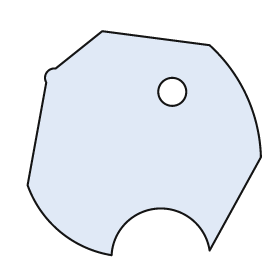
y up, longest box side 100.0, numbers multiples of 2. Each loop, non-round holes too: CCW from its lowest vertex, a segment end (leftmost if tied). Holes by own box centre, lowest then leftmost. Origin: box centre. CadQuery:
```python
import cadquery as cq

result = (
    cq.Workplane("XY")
    .moveTo(-14.0, -48.0)
    .threePointArc((6.0, -28.0), (28.0, -46.0))
    .lineTo(50.0, -6.0)
    .threePointArc((44.0, 20.0), (28.0, 42.0))
    .lineTo(-18.0, 48.0)
    .lineTo(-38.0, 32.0)
    .threePointArc((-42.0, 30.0), (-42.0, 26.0))
    .lineTo(-50.0, -18.0)
    .threePointArc((-36.0, -38.0), (-14.0, -48.0))
    .close()
    .moveTo(12.0, 22.0)
    .circle(6.0)
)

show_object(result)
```